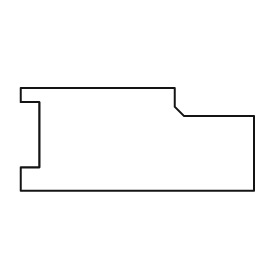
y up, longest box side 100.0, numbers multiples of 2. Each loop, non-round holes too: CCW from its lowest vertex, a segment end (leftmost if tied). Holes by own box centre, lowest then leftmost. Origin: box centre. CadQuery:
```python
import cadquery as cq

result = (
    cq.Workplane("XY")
    .moveTo(-50.0, -22.0)
    .lineTo(50.0, -22.0)
    .lineTo(50.0, 10.0)
    .lineTo(20.0, 10.0)
    .lineTo(16.0, 14.0)
    .lineTo(16.0, 22.0)
    .lineTo(-50.0, 22.0)
    .lineTo(-50.0, 16.0)
    .lineTo(-42.0, 16.0)
    .lineTo(-42.0, -12.0)
    .lineTo(-50.0, -12.0)
    .close()
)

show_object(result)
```